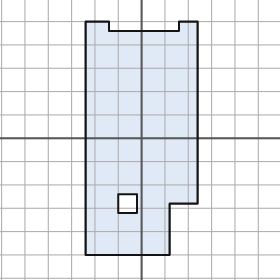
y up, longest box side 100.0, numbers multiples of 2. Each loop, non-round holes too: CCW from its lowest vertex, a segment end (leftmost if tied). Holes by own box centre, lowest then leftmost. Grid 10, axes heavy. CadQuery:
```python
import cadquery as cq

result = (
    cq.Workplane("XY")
    .moveTo(-24.0, -50.0)
    .lineTo(12.0, -50.0)
    .lineTo(12.0, -28.0)
    .lineTo(24.0, -28.0)
    .lineTo(24.0, 50.0)
    .lineTo(16.0, 50.0)
    .lineTo(16.0, 46.0)
    .lineTo(-14.0, 46.0)
    .lineTo(-14.0, 50.0)
    .lineTo(-24.0, 50.0)
    .close()
    .moveTo(-10.0, -32.0)
    .lineTo(-2.0, -32.0)
    .lineTo(-2.0, -24.0)
    .lineTo(-10.0, -24.0)
    .close()
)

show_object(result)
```